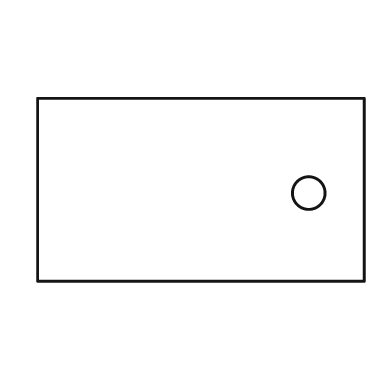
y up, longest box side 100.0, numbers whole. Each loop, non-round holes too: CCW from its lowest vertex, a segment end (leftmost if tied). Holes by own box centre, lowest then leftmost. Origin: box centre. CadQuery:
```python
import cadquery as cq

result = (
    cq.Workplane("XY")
    .moveTo(-50.0, -28.0)
    .lineTo(50.0, -28.0)
    .lineTo(50.0, 28.0)
    .lineTo(-50.0, 28.0)
    .close()
    .moveTo(33.0, -1.0)
    .circle(5.0)
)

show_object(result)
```